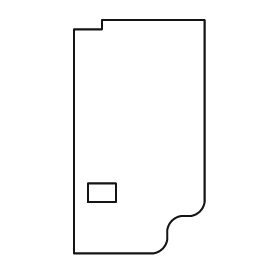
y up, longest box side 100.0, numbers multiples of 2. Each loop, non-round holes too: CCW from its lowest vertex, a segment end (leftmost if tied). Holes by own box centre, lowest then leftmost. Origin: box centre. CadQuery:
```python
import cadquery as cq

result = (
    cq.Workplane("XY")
    .moveTo(-28.0, -50.0)
    .lineTo(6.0, -50.0)
    .threePointArc((10.0, -48.0), (12.0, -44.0))
    .lineTo(12.0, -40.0)
    .threePointArc((14.0, -36.0), (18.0, -34.0))
    .lineTo(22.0, -34.0)
    .threePointArc((26.0, -32.0), (28.0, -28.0))
    .lineTo(28.0, 50.0)
    .lineTo(-16.0, 50.0)
    .lineTo(-16.0, 46.0)
    .lineTo(-28.0, 46.0)
    .close()
    .moveTo(-22.0, -28.0)
    .lineTo(-10.0, -28.0)
    .lineTo(-10.0, -20.0)
    .lineTo(-22.0, -20.0)
    .close()
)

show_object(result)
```